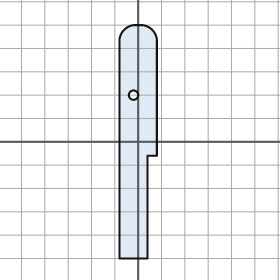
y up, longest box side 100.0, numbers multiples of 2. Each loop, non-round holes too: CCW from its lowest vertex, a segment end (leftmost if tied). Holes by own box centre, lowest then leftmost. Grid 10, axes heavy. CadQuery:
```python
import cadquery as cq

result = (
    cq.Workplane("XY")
    .moveTo(-8.0, -50.0)
    .lineTo(4.0, -50.0)
    .lineTo(4.0, -6.0)
    .lineTo(8.0, -6.0)
    .lineTo(8.0, 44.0)
    .threePointArc((6.0, 48.0), (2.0, 50.0))
    .lineTo(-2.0, 50.0)
    .threePointArc((-6.0, 48.0), (-8.0, 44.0))
    .close()
    .moveTo(-2.0, 20.0)
    .circle(2.0)
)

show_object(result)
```